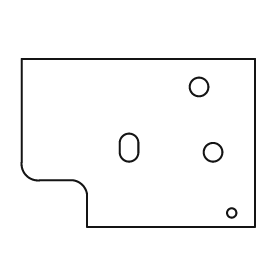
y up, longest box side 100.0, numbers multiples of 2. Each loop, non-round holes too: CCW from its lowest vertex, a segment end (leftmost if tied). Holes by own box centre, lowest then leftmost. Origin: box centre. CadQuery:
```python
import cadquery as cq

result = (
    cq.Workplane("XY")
    .moveTo(-22.0, -36.0)
    .lineTo(50.0, -36.0)
    .lineTo(50.0, 36.0)
    .lineTo(-50.0, 36.0)
    .lineTo(-50.0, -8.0)
    .threePointArc((-48.0, -14.0), (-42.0, -16.0))
    .lineTo(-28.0, -16.0)
    .threePointArc((-24.0, -18.0), (-22.0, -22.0))
    .close()
    .moveTo(40.0, -30.0)
    .circle(2.0)
    .moveTo(32.0, -4.0)
    .circle(4.0)
    .moveTo(-8.0, -4.0)
    .threePointArc((-4.0, -8.0), (0.0, -4.0))
    .lineTo(0.0, 0.0)
    .threePointArc((-4.0, 4.0), (-8.0, 0.0))
    .close()
    .moveTo(26.0, 24.0)
    .circle(4.0)
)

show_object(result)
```